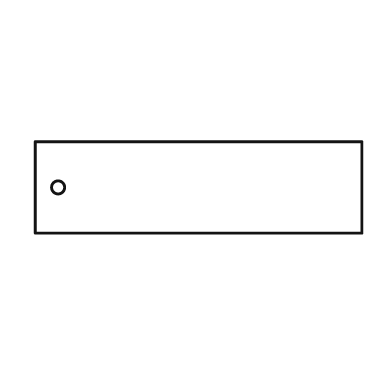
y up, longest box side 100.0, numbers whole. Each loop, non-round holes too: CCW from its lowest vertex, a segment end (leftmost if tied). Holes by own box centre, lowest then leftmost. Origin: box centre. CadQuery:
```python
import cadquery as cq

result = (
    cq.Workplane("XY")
    .moveTo(-50.0, -14.0)
    .lineTo(50.0, -14.0)
    .lineTo(50.0, 14.0)
    .lineTo(-50.0, 14.0)
    .close()
    .moveTo(-43.0, 0.0)
    .circle(2.0)
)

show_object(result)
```